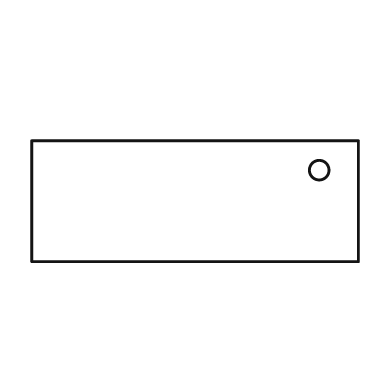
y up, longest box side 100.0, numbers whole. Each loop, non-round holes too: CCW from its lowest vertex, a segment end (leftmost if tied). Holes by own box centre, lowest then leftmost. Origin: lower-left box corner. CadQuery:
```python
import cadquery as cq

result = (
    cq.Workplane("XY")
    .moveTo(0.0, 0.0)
    .lineTo(100.0, 0.0)
    .lineTo(100.0, 37.0)
    .lineTo(0.0, 37.0)
    .close()
    .moveTo(88.0, 28.0)
    .circle(3.0)
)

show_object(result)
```